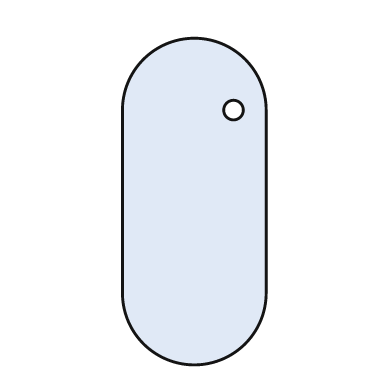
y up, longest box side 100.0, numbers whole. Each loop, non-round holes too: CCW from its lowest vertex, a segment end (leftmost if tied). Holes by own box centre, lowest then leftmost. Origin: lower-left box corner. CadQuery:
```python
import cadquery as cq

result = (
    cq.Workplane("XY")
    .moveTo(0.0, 22.0)
    .threePointArc((22.0, 0.0), (44.0, 22.0))
    .lineTo(44.0, 78.0)
    .threePointArc((22.0, 100.0), (0.0, 78.0))
    .close()
    .moveTo(34.0, 78.0)
    .circle(3.0)
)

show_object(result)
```